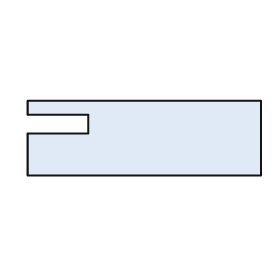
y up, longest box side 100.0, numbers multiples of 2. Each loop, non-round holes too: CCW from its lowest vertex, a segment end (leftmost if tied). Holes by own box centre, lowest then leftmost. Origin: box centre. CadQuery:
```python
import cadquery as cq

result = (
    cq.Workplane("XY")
    .moveTo(-50.0, -16.0)
    .lineTo(50.0, -16.0)
    .lineTo(50.0, 16.0)
    .lineTo(-50.0, 16.0)
    .lineTo(-50.0, 10.0)
    .lineTo(-24.0, 10.0)
    .lineTo(-24.0, 2.0)
    .lineTo(-50.0, 2.0)
    .close()
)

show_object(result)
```